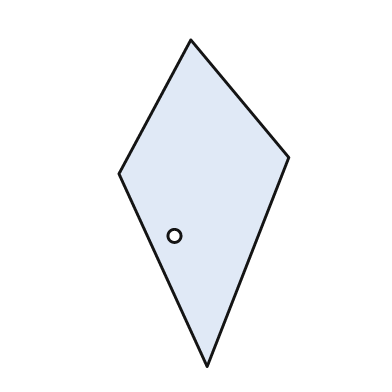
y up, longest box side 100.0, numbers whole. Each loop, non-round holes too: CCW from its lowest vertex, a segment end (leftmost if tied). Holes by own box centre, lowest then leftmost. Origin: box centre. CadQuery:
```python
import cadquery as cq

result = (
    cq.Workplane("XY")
    .moveTo(1.0, -50.0)
    .lineTo(26.0, 14.0)
    .lineTo(-4.0, 50.0)
    .lineTo(-26.0, 9.0)
    .close()
    .moveTo(-9.0, -10.0)
    .circle(2.0)
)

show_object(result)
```